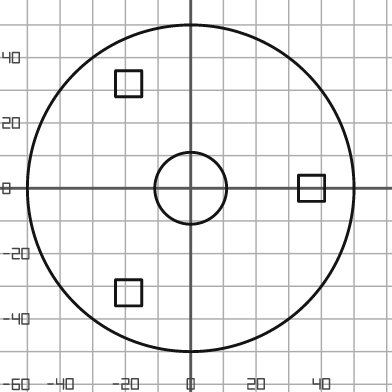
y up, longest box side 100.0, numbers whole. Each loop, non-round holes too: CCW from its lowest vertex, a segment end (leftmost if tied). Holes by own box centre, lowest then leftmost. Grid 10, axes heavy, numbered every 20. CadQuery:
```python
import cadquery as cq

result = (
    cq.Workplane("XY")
    .moveTo(0.0, 0.0)
    .circle(50.0)
    .moveTo(-23.0, -36.0)
    .lineTo(-15.0, -36.0)
    .lineTo(-15.0, -28.0)
    .lineTo(-23.0, -28.0)
    .close()
    .moveTo(0.0, 0.0)
    .circle(11.0)
    .moveTo(33.0, -4.0)
    .lineTo(41.0, -4.0)
    .lineTo(41.0, 4.0)
    .lineTo(33.0, 4.0)
    .close()
    .moveTo(-23.0, 28.0)
    .lineTo(-15.0, 28.0)
    .lineTo(-15.0, 36.0)
    .lineTo(-23.0, 36.0)
    .close()
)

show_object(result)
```